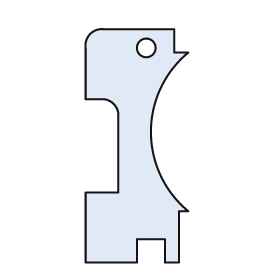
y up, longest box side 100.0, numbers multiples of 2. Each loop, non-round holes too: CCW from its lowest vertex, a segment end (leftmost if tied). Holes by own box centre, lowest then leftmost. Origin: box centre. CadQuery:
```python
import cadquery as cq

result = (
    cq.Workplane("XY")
    .moveTo(-22.0, -50.0)
    .lineTo(0.0, -50.0)
    .lineTo(0.0, -40.0)
    .lineTo(12.0, -40.0)
    .lineTo(12.0, -50.0)
    .lineTo(18.0, -50.0)
    .lineTo(18.0, -28.0)
    .lineTo(22.0, -28.0)
    .threePointArc((6.0, 6.0), (22.0, 40.0))
    .lineTo(16.0, 40.0)
    .lineTo(16.0, 50.0)
    .lineTo(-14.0, 50.0)
    .threePointArc((-20.0, 48.0), (-22.0, 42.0))
    .lineTo(-22.0, 20.0)
    .lineTo(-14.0, 20.0)
    .threePointArc((-10.0, 18.0), (-8.0, 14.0))
    .lineTo(-8.0, -20.0)
    .lineTo(-22.0, -20.0)
    .close()
    .moveTo(4.0, 42.0)
    .circle(4.0)
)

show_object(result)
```